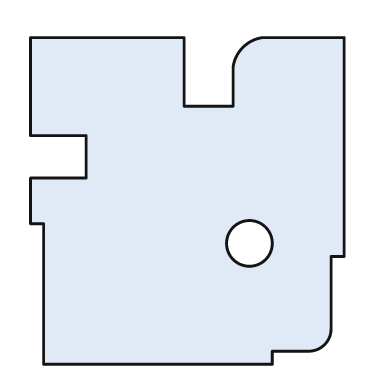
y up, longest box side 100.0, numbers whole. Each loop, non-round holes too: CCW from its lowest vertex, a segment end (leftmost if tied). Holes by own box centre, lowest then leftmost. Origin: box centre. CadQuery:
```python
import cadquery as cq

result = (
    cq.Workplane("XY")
    .moveTo(-44.0, -50.0)
    .lineTo(26.0, -50.0)
    .lineTo(26.0, -46.0)
    .lineTo(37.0, -46.0)
    .threePointArc((42.0, -44.0), (44.0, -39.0))
    .lineTo(44.0, -17.0)
    .lineTo(48.0, -17.0)
    .lineTo(48.0, 50.0)
    .lineTo(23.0, 50.0)
    .threePointArc((17.0, 47.0), (14.0, 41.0))
    .lineTo(14.0, 29.0)
    .lineTo(-1.0, 29.0)
    .lineTo(-1.0, 50.0)
    .lineTo(-48.0, 50.0)
    .lineTo(-48.0, 20.0)
    .lineTo(-31.0, 20.0)
    .lineTo(-31.0, 7.0)
    .lineTo(-48.0, 7.0)
    .lineTo(-48.0, -7.0)
    .lineTo(-44.0, -7.0)
    .close()
    .moveTo(19.0, -13.0)
    .circle(7.0)
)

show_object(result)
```